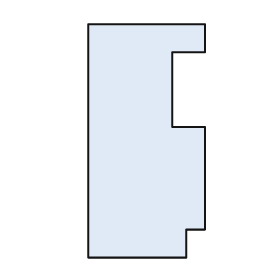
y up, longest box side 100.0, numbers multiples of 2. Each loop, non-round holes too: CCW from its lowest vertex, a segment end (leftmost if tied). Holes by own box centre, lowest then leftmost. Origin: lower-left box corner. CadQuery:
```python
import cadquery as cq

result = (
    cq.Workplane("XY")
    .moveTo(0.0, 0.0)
    .lineTo(42.0, 0.0)
    .lineTo(42.0, 12.0)
    .lineTo(50.0, 12.0)
    .lineTo(50.0, 56.0)
    .lineTo(36.0, 56.0)
    .lineTo(36.0, 88.0)
    .lineTo(50.0, 88.0)
    .lineTo(50.0, 100.0)
    .lineTo(0.0, 100.0)
    .close()
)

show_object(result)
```